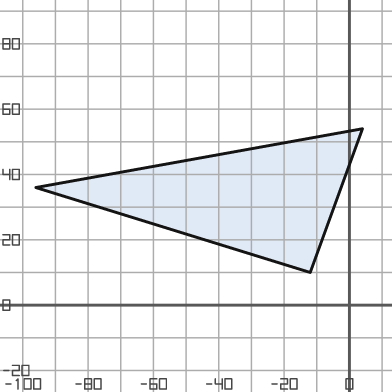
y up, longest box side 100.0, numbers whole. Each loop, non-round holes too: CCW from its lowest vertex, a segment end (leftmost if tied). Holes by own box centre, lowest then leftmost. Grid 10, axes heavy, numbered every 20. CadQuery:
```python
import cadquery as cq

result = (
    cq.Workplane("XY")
    .moveTo(-12.0, 10.0)
    .lineTo(4.0, 54.0)
    .lineTo(-96.0, 36.0)
    .close()
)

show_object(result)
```